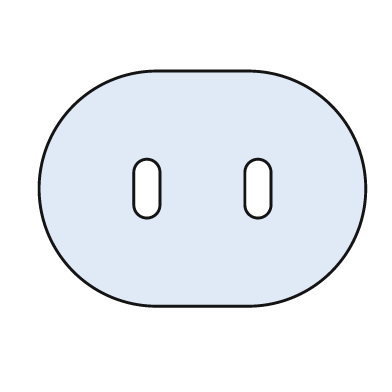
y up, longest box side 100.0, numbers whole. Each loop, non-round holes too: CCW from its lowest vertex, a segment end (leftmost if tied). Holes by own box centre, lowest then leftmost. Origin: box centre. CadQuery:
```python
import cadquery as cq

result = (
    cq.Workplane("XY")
    .moveTo(-14.0, -36.0)
    .lineTo(14.0, -36.0)
    .threePointArc((50.0, 0.0), (14.0, 36.0))
    .lineTo(-14.0, 36.0)
    .threePointArc((-50.0, 0.0), (-14.0, -36.0))
    .close()
    .moveTo(-21.0, -5.0)
    .threePointArc((-17.0, -9.0), (-13.0, -5.0))
    .lineTo(-13.0, 5.0)
    .threePointArc((-17.0, 9.0), (-21.0, 5.0))
    .close()
    .moveTo(13.0, -5.0)
    .threePointArc((17.0, -9.0), (21.0, -5.0))
    .lineTo(21.0, 5.0)
    .threePointArc((17.0, 9.0), (13.0, 5.0))
    .close()
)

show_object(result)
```